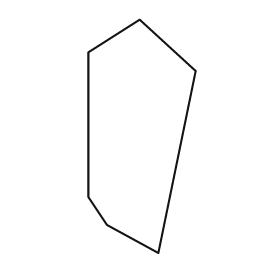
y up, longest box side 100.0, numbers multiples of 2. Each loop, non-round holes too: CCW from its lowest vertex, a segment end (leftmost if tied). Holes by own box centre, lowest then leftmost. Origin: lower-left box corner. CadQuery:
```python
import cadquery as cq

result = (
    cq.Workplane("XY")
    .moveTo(30.0, 0.0)
    .lineTo(46.0, 78.0)
    .lineTo(22.0, 100.0)
    .lineTo(0.0, 86.0)
    .lineTo(0.0, 24.0)
    .lineTo(8.0, 12.0)
    .close()
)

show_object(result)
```